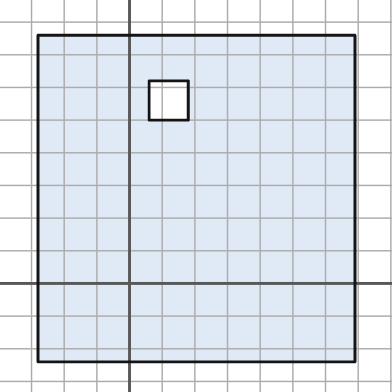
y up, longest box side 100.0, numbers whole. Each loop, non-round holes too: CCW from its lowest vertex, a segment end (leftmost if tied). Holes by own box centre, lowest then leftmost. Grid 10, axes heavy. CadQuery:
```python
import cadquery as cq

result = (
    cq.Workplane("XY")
    .moveTo(-28.0, -24.0)
    .lineTo(69.0, -24.0)
    .lineTo(69.0, 76.0)
    .lineTo(-28.0, 76.0)
    .close()
    .moveTo(6.0, 50.0)
    .lineTo(18.0, 50.0)
    .lineTo(18.0, 62.0)
    .lineTo(6.0, 62.0)
    .close()
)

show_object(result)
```